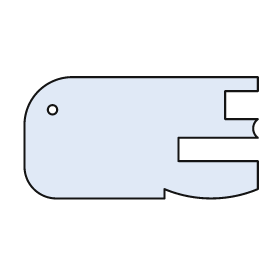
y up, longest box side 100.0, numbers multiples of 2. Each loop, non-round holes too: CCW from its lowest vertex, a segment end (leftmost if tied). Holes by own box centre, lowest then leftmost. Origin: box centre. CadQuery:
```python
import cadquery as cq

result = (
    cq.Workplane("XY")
    .moveTo(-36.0, -26.0)
    .lineTo(10.0, -26.0)
    .lineTo(10.0, -22.0)
    .threePointArc((30.0, -26.0), (50.0, -22.0))
    .lineTo(50.0, -10.0)
    .lineTo(16.0, -10.0)
    .lineTo(16.0, 0.0)
    .lineTo(50.0, 0.0)
    .threePointArc((48.0, 4.0), (50.0, 8.0))
    .lineTo(36.0, 8.0)
    .lineTo(36.0, 20.0)
    .lineTo(50.0, 20.0)
    .lineTo(50.0, 26.0)
    .lineTo(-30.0, 26.0)
    .threePointArc((-44.0, 20.0), (-50.0, 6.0))
    .lineTo(-50.0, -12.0)
    .threePointArc((-46.0, -22.0), (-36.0, -26.0))
    .close()
    .moveTo(-38.0, 12.0)
    .circle(2.0)
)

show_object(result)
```